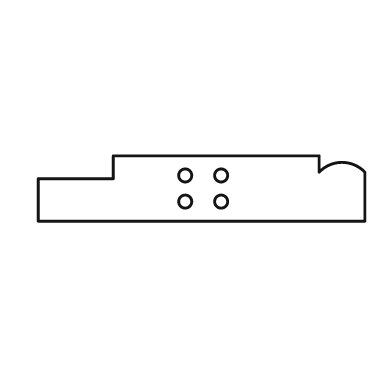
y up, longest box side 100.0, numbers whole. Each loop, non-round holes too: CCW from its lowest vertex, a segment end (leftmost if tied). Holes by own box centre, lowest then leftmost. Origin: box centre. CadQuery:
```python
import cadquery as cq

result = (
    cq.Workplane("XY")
    .moveTo(-50.0, -10.0)
    .lineTo(50.0, -10.0)
    .lineTo(50.0, 5.0)
    .threePointArc((43.0, 8.0), (36.0, 5.0))
    .lineTo(36.0, 10.0)
    .lineTo(-27.0, 10.0)
    .lineTo(-27.0, 3.0)
    .lineTo(-50.0, 3.0)
    .close()
    .moveTo(-5.0, -4.0)
    .circle(2.0)
    .moveTo(6.0, -4.0)
    .circle(2.0)
    .moveTo(-5.0, 4.0)
    .circle(2.0)
    .moveTo(6.0, 4.0)
    .circle(2.0)
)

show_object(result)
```